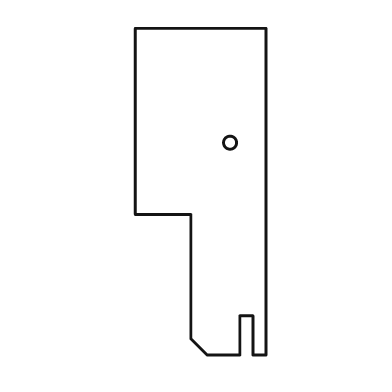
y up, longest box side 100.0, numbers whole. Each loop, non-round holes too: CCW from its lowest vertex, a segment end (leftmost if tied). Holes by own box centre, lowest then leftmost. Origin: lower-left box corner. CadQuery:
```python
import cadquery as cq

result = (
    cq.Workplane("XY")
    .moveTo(22.0, 0.0)
    .lineTo(32.0, 0.0)
    .lineTo(32.0, 12.0)
    .lineTo(36.0, 12.0)
    .lineTo(36.0, 0.0)
    .lineTo(40.0, 0.0)
    .lineTo(40.0, 100.0)
    .lineTo(0.0, 100.0)
    .lineTo(0.0, 43.0)
    .lineTo(17.0, 43.0)
    .lineTo(17.0, 5.0)
    .close()
    .moveTo(29.0, 65.0)
    .circle(2.0)
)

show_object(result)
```